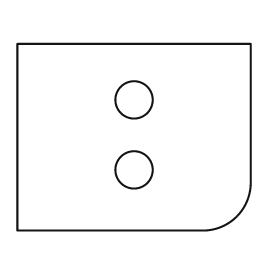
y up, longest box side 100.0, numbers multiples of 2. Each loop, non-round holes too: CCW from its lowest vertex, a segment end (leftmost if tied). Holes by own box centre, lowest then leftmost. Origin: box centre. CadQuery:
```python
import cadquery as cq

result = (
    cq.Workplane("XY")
    .moveTo(-50.0, -40.0)
    .lineTo(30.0, -40.0)
    .threePointArc((44.0, -34.0), (50.0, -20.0))
    .lineTo(50.0, 40.0)
    .lineTo(-50.0, 40.0)
    .close()
    .moveTo(0.0, -14.0)
    .circle(8.0)
    .moveTo(0.0, 16.0)
    .circle(8.0)
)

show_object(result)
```